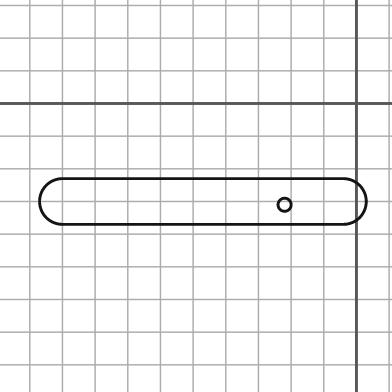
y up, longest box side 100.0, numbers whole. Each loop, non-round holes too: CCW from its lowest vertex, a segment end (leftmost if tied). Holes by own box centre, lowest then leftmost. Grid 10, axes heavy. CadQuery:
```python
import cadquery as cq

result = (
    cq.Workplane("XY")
    .moveTo(-90.0, -37.0)
    .lineTo(-4.0, -37.0)
    .threePointArc((3.0, -30.0), (-4.0, -23.0))
    .lineTo(-90.0, -23.0)
    .threePointArc((-97.0, -30.0), (-90.0, -37.0))
    .close()
    .moveTo(-22.0, -31.0)
    .circle(2.0)
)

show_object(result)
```